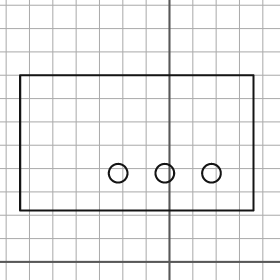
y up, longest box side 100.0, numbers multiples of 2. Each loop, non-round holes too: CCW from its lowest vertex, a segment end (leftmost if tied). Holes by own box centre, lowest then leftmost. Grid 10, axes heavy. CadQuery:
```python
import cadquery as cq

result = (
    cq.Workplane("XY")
    .moveTo(-64.0, 22.0)
    .lineTo(36.0, 22.0)
    .lineTo(36.0, 80.0)
    .lineTo(-64.0, 80.0)
    .close()
    .moveTo(-22.0, 38.0)
    .circle(4.0)
    .moveTo(-2.0, 38.0)
    .circle(4.0)
    .moveTo(18.0, 38.0)
    .circle(4.0)
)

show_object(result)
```